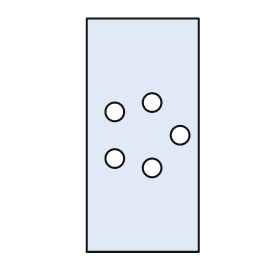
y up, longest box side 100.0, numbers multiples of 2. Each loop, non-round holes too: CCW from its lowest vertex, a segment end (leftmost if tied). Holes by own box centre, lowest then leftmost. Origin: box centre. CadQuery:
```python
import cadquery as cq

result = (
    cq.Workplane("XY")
    .moveTo(-24.0, -50.0)
    .lineTo(24.0, -50.0)
    .lineTo(24.0, 50.0)
    .lineTo(-24.0, 50.0)
    .close()
    .moveTo(4.0, -14.0)
    .circle(4.0)
    .moveTo(-12.0, -10.0)
    .circle(4.0)
    .moveTo(16.0, 0.0)
    .circle(4.0)
    .moveTo(-12.0, 10.0)
    .circle(4.0)
    .moveTo(4.0, 14.0)
    .circle(4.0)
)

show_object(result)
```